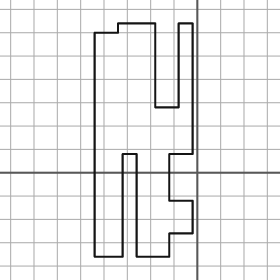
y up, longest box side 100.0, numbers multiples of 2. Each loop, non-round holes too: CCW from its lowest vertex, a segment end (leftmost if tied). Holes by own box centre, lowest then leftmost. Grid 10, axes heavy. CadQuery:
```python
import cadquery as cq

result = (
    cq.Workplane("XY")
    .moveTo(-44.0, -36.0)
    .lineTo(-32.0, -36.0)
    .lineTo(-32.0, 8.0)
    .lineTo(-26.0, 8.0)
    .lineTo(-26.0, -36.0)
    .lineTo(-12.0, -36.0)
    .lineTo(-12.0, -26.0)
    .lineTo(-2.0, -26.0)
    .lineTo(-2.0, -12.0)
    .lineTo(-12.0, -12.0)
    .lineTo(-12.0, 8.0)
    .lineTo(-2.0, 8.0)
    .lineTo(-2.0, 64.0)
    .lineTo(-8.0, 64.0)
    .lineTo(-8.0, 28.0)
    .lineTo(-18.0, 28.0)
    .lineTo(-18.0, 64.0)
    .lineTo(-34.0, 64.0)
    .lineTo(-34.0, 60.0)
    .lineTo(-44.0, 60.0)
    .close()
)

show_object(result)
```